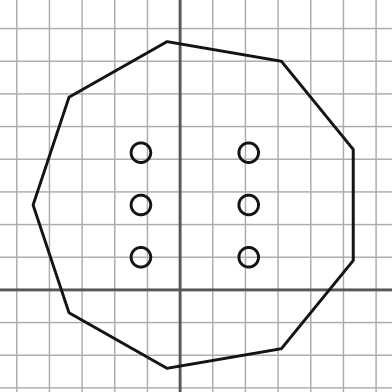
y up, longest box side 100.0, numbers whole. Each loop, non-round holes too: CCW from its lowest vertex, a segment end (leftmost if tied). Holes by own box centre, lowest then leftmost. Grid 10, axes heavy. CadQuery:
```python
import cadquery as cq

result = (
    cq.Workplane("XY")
    .moveTo(-4.0, -24.0)
    .lineTo(31.0, -18.0)
    .lineTo(53.0, 9.0)
    .lineTo(53.0, 43.0)
    .lineTo(31.0, 70.0)
    .lineTo(-4.0, 76.0)
    .lineTo(-34.0, 59.0)
    .lineTo(-45.0, 26.0)
    .lineTo(-34.0, -7.0)
    .close()
    .moveTo(-12.0, 10.0)
    .circle(3.0)
    .moveTo(21.0, 10.0)
    .circle(3.0)
    .moveTo(-12.0, 26.0)
    .circle(3.0)
    .moveTo(21.0, 26.0)
    .circle(3.0)
    .moveTo(-12.0, 42.0)
    .circle(3.0)
    .moveTo(21.0, 42.0)
    .circle(3.0)
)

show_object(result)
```